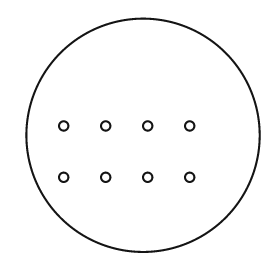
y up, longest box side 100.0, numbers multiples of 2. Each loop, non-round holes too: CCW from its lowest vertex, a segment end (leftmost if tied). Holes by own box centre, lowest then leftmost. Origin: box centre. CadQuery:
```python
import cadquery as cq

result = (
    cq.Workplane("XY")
    .moveTo(0.0, 0.0)
    .circle(50.0)
    .moveTo(-34.0, -18.0)
    .circle(2.0)
    .moveTo(-16.0, -18.0)
    .circle(2.0)
    .moveTo(2.0, -18.0)
    .circle(2.0)
    .moveTo(20.0, -18.0)
    .circle(2.0)
    .moveTo(-34.0, 4.0)
    .circle(2.0)
    .moveTo(-16.0, 4.0)
    .circle(2.0)
    .moveTo(2.0, 4.0)
    .circle(2.0)
    .moveTo(20.0, 4.0)
    .circle(2.0)
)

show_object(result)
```